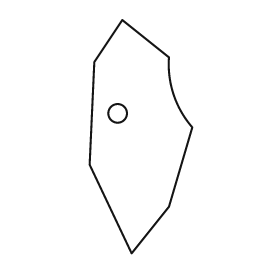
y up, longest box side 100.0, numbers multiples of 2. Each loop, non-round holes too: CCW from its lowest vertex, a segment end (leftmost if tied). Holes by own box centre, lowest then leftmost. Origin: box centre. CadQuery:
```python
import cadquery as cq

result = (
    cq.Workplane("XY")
    .moveTo(-4.0, -50.0)
    .lineTo(12.0, -30.0)
    .lineTo(22.0, 4.0)
    .threePointArc((14.0, 18.0), (12.0, 34.0))
    .lineTo(-8.0, 50.0)
    .lineTo(-20.0, 32.0)
    .lineTo(-22.0, -12.0)
    .close()
    .moveTo(-10.0, 10.0)
    .circle(4.0)
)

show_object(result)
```